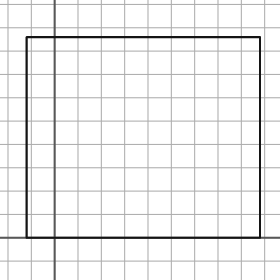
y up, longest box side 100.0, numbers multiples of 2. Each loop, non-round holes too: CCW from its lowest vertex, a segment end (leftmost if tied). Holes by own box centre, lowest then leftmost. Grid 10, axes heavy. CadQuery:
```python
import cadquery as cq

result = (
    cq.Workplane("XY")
    .moveTo(-12.0, 0.0)
    .lineTo(88.0, 0.0)
    .lineTo(88.0, 86.0)
    .lineTo(-12.0, 86.0)
    .close()
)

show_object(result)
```